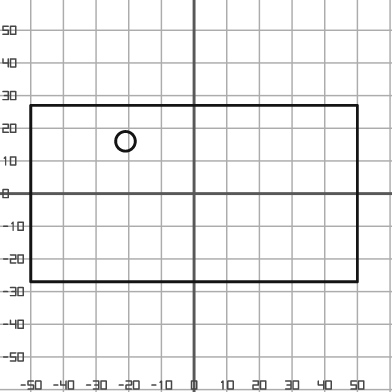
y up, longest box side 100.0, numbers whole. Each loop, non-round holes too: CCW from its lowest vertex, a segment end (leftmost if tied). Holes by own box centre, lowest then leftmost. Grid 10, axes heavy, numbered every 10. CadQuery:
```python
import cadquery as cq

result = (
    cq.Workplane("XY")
    .moveTo(-50.0, -27.0)
    .lineTo(50.0, -27.0)
    .lineTo(50.0, 27.0)
    .lineTo(-50.0, 27.0)
    .close()
    .moveTo(-21.0, 16.0)
    .circle(3.0)
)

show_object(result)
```